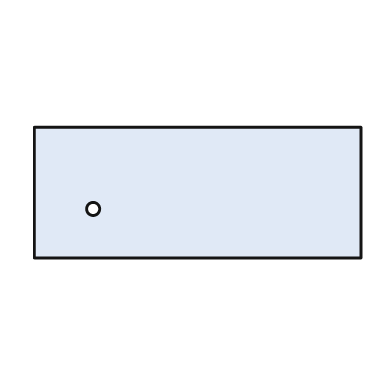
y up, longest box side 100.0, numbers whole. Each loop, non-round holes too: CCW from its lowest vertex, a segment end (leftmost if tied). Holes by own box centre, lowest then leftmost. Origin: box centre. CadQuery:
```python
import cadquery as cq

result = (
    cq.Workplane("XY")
    .moveTo(-50.0, -20.0)
    .lineTo(50.0, -20.0)
    .lineTo(50.0, 20.0)
    .lineTo(-50.0, 20.0)
    .close()
    .moveTo(-32.0, -5.0)
    .circle(2.0)
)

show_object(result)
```